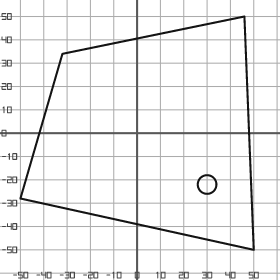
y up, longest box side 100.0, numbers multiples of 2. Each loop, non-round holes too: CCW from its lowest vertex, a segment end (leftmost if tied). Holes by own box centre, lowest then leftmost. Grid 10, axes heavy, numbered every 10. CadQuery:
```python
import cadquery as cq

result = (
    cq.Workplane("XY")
    .moveTo(50.0, -50.0)
    .lineTo(46.0, 50.0)
    .lineTo(-32.0, 34.0)
    .lineTo(-50.0, -28.0)
    .close()
    .moveTo(30.0, -22.0)
    .circle(4.0)
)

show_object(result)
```